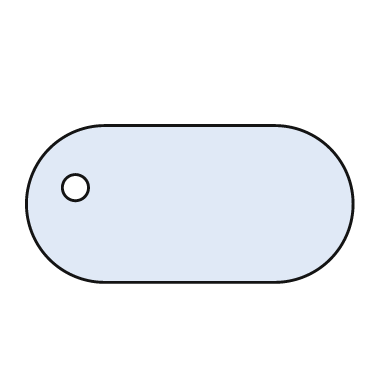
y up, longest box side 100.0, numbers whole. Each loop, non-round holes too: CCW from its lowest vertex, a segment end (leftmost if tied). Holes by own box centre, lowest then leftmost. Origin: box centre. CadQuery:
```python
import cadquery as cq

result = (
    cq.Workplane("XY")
    .moveTo(-26.0, -24.0)
    .lineTo(26.0, -24.0)
    .threePointArc((50.0, 0.0), (26.0, 24.0))
    .lineTo(-26.0, 24.0)
    .threePointArc((-50.0, 0.0), (-26.0, -24.0))
    .close()
    .moveTo(-35.0, 5.0)
    .circle(4.0)
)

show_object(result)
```